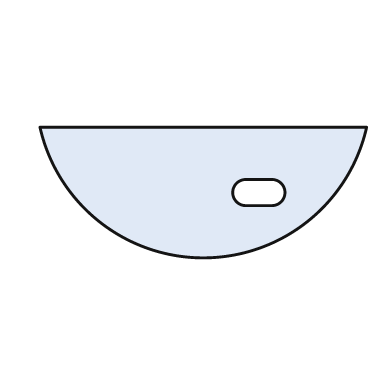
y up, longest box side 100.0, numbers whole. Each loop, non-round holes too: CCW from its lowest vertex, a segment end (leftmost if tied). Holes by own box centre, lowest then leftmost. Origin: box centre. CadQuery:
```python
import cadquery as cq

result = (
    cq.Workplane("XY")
    .moveTo(-50.0, 20.0)
    .threePointArc((0.0, -20.0), (50.0, 20.0))
    .close()
    .moveTo(13.0, -4.0)
    .lineTo(21.0, -4.0)
    .threePointArc((25.0, 0.0), (21.0, 4.0))
    .lineTo(13.0, 4.0)
    .threePointArc((9.0, 0.0), (13.0, -4.0))
    .close()
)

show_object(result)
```